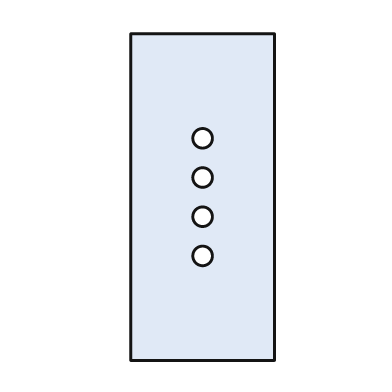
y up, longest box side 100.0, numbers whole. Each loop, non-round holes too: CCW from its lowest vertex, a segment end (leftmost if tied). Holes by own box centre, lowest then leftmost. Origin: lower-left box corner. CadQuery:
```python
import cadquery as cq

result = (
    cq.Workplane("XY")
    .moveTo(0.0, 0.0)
    .lineTo(44.0, 0.0)
    .lineTo(44.0, 100.0)
    .lineTo(0.0, 100.0)
    .close()
    .moveTo(22.0, 32.0)
    .circle(3.0)
    .moveTo(22.0, 44.0)
    .circle(3.0)
    .moveTo(22.0, 56.0)
    .circle(3.0)
    .moveTo(22.0, 68.0)
    .circle(3.0)
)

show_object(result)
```